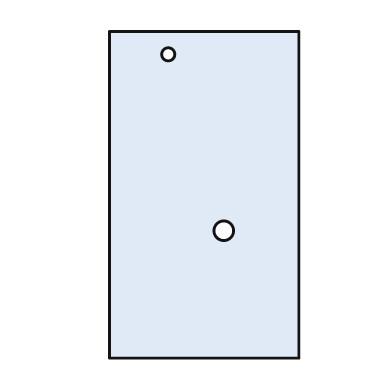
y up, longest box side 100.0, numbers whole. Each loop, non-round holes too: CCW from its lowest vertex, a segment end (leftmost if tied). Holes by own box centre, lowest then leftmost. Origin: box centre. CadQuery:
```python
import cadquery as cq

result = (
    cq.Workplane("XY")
    .moveTo(-29.0, -50.0)
    .lineTo(29.0, -50.0)
    .lineTo(29.0, 50.0)
    .lineTo(-29.0, 50.0)
    .close()
    .moveTo(6.0, -11.0)
    .circle(3.0)
    .moveTo(-11.0, 43.0)
    .circle(2.0)
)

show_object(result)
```